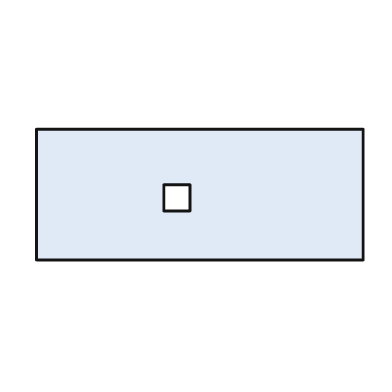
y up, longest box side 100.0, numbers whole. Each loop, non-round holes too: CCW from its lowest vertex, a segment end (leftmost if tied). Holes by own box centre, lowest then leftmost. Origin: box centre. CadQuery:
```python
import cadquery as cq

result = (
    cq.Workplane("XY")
    .moveTo(-50.0, -20.0)
    .lineTo(50.0, -20.0)
    .lineTo(50.0, 20.0)
    .lineTo(-50.0, 20.0)
    .close()
    .moveTo(-11.0, -5.0)
    .lineTo(-3.0, -5.0)
    .lineTo(-3.0, 3.0)
    .lineTo(-11.0, 3.0)
    .close()
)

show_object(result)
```